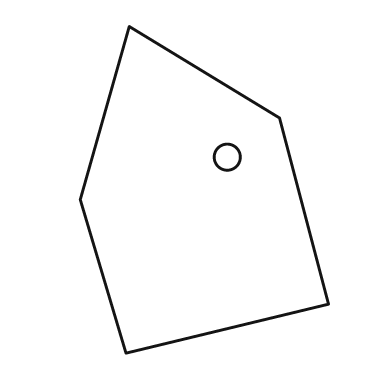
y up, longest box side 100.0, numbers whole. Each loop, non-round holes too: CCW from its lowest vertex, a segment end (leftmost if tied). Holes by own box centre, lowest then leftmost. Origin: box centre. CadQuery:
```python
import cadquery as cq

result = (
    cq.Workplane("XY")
    .moveTo(-24.0, -50.0)
    .lineTo(38.0, -35.0)
    .lineTo(23.0, 22.0)
    .lineTo(-23.0, 50.0)
    .lineTo(-38.0, -3.0)
    .close()
    .moveTo(7.0, 10.0)
    .circle(4.0)
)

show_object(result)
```